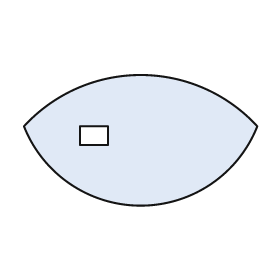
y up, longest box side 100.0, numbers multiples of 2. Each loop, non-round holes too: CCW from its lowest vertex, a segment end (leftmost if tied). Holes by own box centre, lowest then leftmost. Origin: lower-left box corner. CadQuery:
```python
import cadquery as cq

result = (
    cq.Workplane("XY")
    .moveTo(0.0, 34.0)
    .threePointArc((50.0, 0.0), (100.0, 34.0))
    .threePointArc((50.0, 56.0), (0.0, 34.0))
    .close()
    .moveTo(24.0, 26.0)
    .lineTo(36.0, 26.0)
    .lineTo(36.0, 34.0)
    .lineTo(24.0, 34.0)
    .close()
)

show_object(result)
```